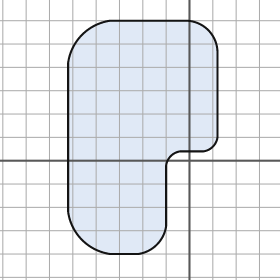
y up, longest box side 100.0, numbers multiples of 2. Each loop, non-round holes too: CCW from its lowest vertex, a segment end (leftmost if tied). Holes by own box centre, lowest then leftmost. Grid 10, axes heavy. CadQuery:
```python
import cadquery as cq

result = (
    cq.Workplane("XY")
    .moveTo(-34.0, -40.0)
    .lineTo(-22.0, -40.0)
    .threePointArc((-14.0, -36.0), (-10.0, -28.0))
    .lineTo(-10.0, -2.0)
    .threePointArc((-8.0, 2.0), (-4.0, 4.0))
    .lineTo(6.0, 4.0)
    .threePointArc((10.0, 6.0), (12.0, 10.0))
    .lineTo(12.0, 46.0)
    .threePointArc((8.0, 56.0), (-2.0, 60.0))
    .lineTo(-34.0, 60.0)
    .threePointArc((-46.0, 54.0), (-52.0, 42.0))
    .lineTo(-52.0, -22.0)
    .threePointArc((-46.0, -34.0), (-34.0, -40.0))
    .close()
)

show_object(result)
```